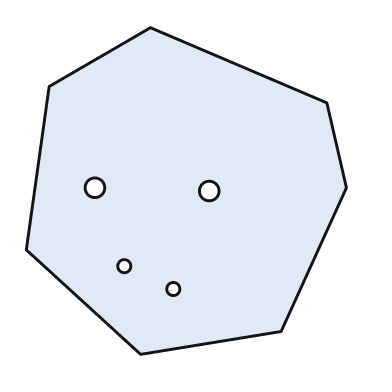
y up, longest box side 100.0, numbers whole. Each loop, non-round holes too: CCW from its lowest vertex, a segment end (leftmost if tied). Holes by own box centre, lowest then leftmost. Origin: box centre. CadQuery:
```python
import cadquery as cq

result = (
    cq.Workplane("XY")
    .moveTo(-14.0, -50.0)
    .lineTo(29.0, -43.0)
    .lineTo(49.0, 1.0)
    .lineTo(43.0, 27.0)
    .lineTo(-11.0, 50.0)
    .lineTo(-42.0, 32.0)
    .lineTo(-49.0, -18.0)
    .close()
    .moveTo(-4.0, -30.0)
    .circle(2.0)
    .moveTo(-19.0, -23.0)
    .circle(2.0)
    .moveTo(7.0, 0.0)
    .circle(3.0)
    .moveTo(-28.0, 1.0)
    .circle(3.0)
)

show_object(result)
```